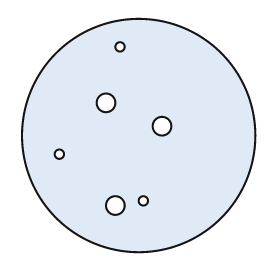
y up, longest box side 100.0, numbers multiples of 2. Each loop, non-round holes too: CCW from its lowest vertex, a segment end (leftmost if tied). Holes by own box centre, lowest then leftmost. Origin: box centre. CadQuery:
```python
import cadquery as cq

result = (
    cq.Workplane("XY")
    .moveTo(0.0, 0.0)
    .circle(50.0)
    .moveTo(-10.0, -30.0)
    .circle(4.0)
    .moveTo(2.0, -28.0)
    .circle(2.0)
    .moveTo(-34.0, -8.0)
    .circle(2.0)
    .moveTo(10.0, 4.0)
    .circle(4.0)
    .moveTo(-14.0, 14.0)
    .circle(4.0)
    .moveTo(-8.0, 38.0)
    .circle(2.0)
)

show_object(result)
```